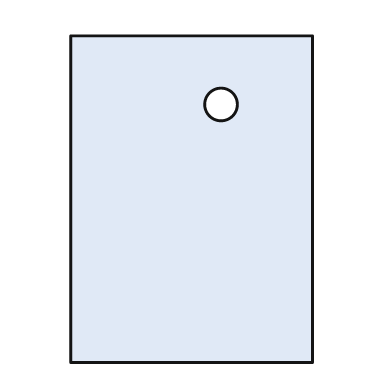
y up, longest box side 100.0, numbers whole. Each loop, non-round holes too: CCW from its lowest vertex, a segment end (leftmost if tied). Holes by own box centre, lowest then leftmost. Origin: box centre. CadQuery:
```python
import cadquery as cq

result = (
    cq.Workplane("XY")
    .moveTo(-37.0, -50.0)
    .lineTo(37.0, -50.0)
    .lineTo(37.0, 50.0)
    .lineTo(-37.0, 50.0)
    .close()
    .moveTo(9.0, 29.0)
    .circle(5.0)
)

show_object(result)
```